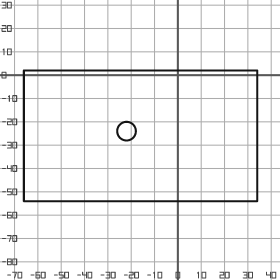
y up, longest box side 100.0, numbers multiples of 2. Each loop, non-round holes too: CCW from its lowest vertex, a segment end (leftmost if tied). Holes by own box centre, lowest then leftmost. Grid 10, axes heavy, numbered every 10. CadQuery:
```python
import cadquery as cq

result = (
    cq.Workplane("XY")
    .moveTo(-66.0, -54.0)
    .lineTo(34.0, -54.0)
    .lineTo(34.0, 2.0)
    .lineTo(-66.0, 2.0)
    .close()
    .moveTo(-22.0, -24.0)
    .circle(4.0)
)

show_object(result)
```